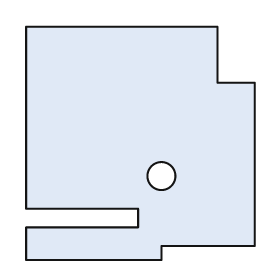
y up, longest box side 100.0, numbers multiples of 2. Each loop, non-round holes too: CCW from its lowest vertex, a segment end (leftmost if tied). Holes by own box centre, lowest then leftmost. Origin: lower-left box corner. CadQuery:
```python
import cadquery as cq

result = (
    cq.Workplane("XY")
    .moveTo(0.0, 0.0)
    .lineTo(58.0, 0.0)
    .lineTo(58.0, 6.0)
    .lineTo(98.0, 6.0)
    .lineTo(98.0, 76.0)
    .lineTo(82.0, 76.0)
    .lineTo(82.0, 100.0)
    .lineTo(0.0, 100.0)
    .lineTo(0.0, 22.0)
    .lineTo(48.0, 22.0)
    .lineTo(48.0, 14.0)
    .lineTo(0.0, 14.0)
    .close()
    .moveTo(58.0, 36.0)
    .circle(6.0)
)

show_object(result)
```